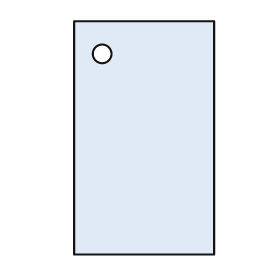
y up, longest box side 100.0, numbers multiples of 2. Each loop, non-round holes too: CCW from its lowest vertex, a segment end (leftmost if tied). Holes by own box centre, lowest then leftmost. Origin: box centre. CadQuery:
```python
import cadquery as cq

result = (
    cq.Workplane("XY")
    .moveTo(-30.0, -50.0)
    .lineTo(30.0, -50.0)
    .lineTo(30.0, 50.0)
    .lineTo(-30.0, 50.0)
    .close()
    .moveTo(-18.0, 36.0)
    .circle(4.0)
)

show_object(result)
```